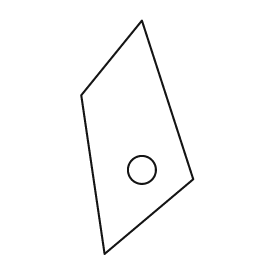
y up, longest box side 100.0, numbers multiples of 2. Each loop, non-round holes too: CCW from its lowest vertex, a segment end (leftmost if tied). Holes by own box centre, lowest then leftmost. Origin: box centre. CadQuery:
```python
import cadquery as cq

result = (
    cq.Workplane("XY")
    .moveTo(-14.0, -50.0)
    .lineTo(24.0, -18.0)
    .lineTo(2.0, 50.0)
    .lineTo(-24.0, 18.0)
    .close()
    .moveTo(2.0, -14.0)
    .circle(6.0)
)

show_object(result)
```